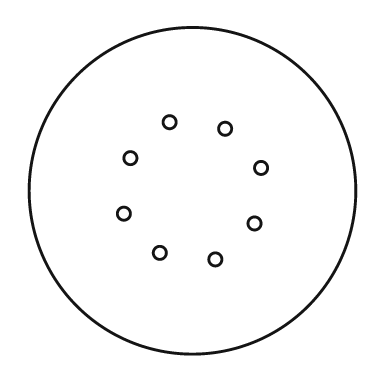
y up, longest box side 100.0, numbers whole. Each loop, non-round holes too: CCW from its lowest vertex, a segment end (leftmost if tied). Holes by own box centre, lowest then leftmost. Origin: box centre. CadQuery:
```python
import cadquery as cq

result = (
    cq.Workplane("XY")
    .moveTo(0.0, 0.0)
    .circle(50.0)
    .moveTo(7.0, -21.0)
    .circle(2.0)
    .moveTo(-10.0, -19.0)
    .circle(2.0)
    .moveTo(19.0, -10.0)
    .circle(2.0)
    .moveTo(-21.0, -7.0)
    .circle(2.0)
    .moveTo(21.0, 7.0)
    .circle(2.0)
    .moveTo(-19.0, 10.0)
    .circle(2.0)
    .moveTo(10.0, 19.0)
    .circle(2.0)
    .moveTo(-7.0, 21.0)
    .circle(2.0)
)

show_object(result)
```